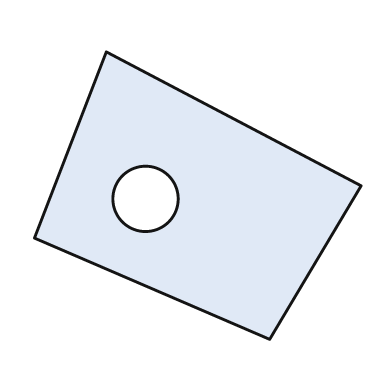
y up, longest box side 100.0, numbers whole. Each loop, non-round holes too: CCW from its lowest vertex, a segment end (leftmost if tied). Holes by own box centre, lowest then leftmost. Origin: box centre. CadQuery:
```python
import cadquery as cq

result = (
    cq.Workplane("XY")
    .moveTo(22.0, -44.0)
    .lineTo(50.0, 3.0)
    .lineTo(-28.0, 44.0)
    .lineTo(-50.0, -13.0)
    .close()
    .moveTo(-16.0, -1.0)
    .circle(10.0)
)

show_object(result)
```